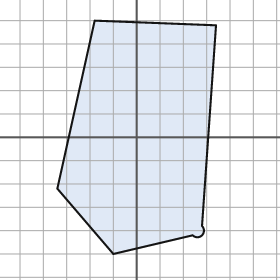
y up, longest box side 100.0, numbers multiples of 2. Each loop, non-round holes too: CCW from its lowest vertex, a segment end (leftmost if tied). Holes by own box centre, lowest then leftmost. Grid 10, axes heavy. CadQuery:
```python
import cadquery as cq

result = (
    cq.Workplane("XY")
    .moveTo(-10.0, -50.0)
    .lineTo(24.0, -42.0)
    .threePointArc((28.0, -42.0), (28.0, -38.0))
    .lineTo(34.0, 48.0)
    .lineTo(-18.0, 50.0)
    .lineTo(-34.0, -22.0)
    .close()
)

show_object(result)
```